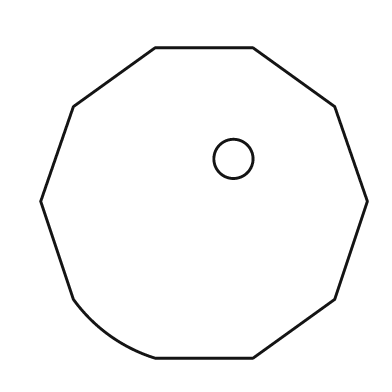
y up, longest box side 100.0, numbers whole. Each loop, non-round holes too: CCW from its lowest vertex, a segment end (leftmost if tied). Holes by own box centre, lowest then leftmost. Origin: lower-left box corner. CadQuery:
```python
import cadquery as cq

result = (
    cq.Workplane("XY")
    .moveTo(35.0, 0.0)
    .lineTo(65.0, 0.0)
    .lineTo(90.0, 18.0)
    .lineTo(100.0, 48.0)
    .lineTo(90.0, 77.0)
    .lineTo(65.0, 95.0)
    .lineTo(35.0, 95.0)
    .lineTo(10.0, 77.0)
    .lineTo(0.0, 48.0)
    .lineTo(10.0, 18.0)
    .threePointArc((21.0, 7.0), (35.0, 0.0))
    .close()
    .moveTo(59.0, 61.0)
    .circle(6.0)
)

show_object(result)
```